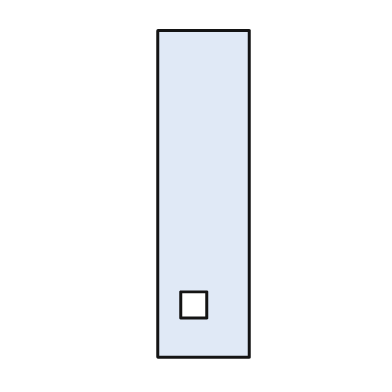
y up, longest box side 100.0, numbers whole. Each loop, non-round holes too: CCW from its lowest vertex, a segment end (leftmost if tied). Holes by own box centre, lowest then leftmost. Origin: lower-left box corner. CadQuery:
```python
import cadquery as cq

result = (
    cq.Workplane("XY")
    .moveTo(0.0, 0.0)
    .lineTo(28.0, 0.0)
    .lineTo(28.0, 100.0)
    .lineTo(0.0, 100.0)
    .close()
    .moveTo(7.0, 12.0)
    .lineTo(15.0, 12.0)
    .lineTo(15.0, 20.0)
    .lineTo(7.0, 20.0)
    .close()
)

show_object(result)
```